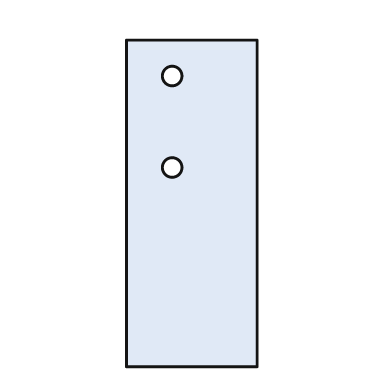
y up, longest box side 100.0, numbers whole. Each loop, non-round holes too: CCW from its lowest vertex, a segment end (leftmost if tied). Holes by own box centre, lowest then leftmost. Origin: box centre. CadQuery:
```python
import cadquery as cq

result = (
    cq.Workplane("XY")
    .moveTo(-20.0, -50.0)
    .lineTo(20.0, -50.0)
    .lineTo(20.0, 50.0)
    .lineTo(-20.0, 50.0)
    .close()
    .moveTo(-6.0, 11.0)
    .circle(3.0)
    .moveTo(-6.0, 39.0)
    .circle(3.0)
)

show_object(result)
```